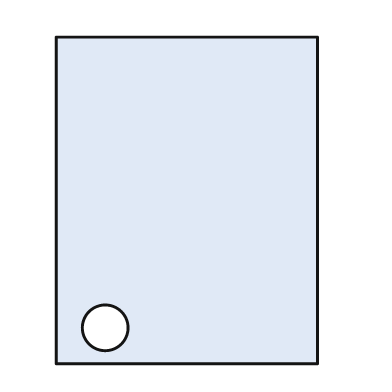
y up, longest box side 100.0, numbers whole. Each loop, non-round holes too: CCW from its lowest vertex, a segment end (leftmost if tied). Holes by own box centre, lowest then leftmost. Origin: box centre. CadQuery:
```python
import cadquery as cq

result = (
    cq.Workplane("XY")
    .moveTo(-40.0, -50.0)
    .lineTo(40.0, -50.0)
    .lineTo(40.0, 50.0)
    .lineTo(-40.0, 50.0)
    .close()
    .moveTo(-25.0, -39.0)
    .circle(7.0)
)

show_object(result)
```